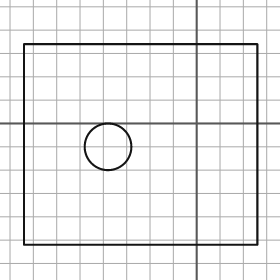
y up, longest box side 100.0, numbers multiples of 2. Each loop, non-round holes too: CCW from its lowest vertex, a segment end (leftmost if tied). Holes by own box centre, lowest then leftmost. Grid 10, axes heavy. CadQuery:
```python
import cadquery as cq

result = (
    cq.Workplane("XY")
    .moveTo(-74.0, -52.0)
    .lineTo(26.0, -52.0)
    .lineTo(26.0, 34.0)
    .lineTo(-74.0, 34.0)
    .close()
    .moveTo(-38.0, -10.0)
    .circle(10.0)
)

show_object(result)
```